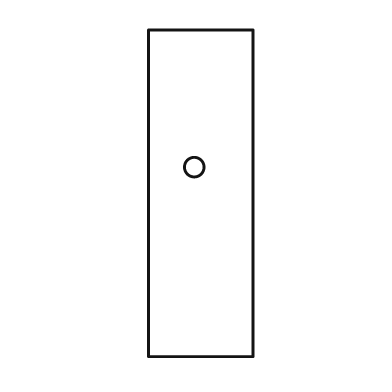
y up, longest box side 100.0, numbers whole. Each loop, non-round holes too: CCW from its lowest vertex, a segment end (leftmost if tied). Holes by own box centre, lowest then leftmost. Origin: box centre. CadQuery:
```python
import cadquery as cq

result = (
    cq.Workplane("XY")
    .moveTo(-16.0, -50.0)
    .lineTo(16.0, -50.0)
    .lineTo(16.0, 50.0)
    .lineTo(-16.0, 50.0)
    .close()
    .moveTo(-2.0, 8.0)
    .circle(3.0)
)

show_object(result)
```